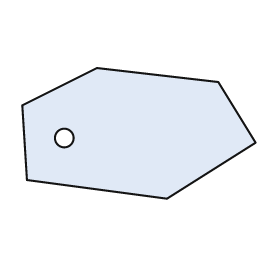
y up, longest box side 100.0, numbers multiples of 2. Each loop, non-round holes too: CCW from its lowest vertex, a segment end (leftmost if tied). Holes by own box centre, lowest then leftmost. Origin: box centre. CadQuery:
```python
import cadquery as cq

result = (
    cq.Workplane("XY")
    .moveTo(12.0, -28.0)
    .lineTo(50.0, -4.0)
    .lineTo(34.0, 22.0)
    .lineTo(-18.0, 28.0)
    .lineTo(-50.0, 12.0)
    .lineTo(-48.0, -20.0)
    .close()
    .moveTo(-32.0, -2.0)
    .circle(4.0)
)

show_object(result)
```